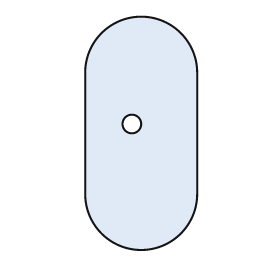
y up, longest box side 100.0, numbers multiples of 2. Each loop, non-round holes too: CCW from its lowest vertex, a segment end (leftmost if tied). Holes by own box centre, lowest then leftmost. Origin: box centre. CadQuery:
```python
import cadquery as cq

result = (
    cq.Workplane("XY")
    .moveTo(-24.0, -26.0)
    .threePointArc((0.0, -50.0), (24.0, -26.0))
    .lineTo(24.0, 26.0)
    .threePointArc((0.0, 50.0), (-24.0, 26.0))
    .close()
    .moveTo(-4.0, 4.0)
    .circle(4.0)
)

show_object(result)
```